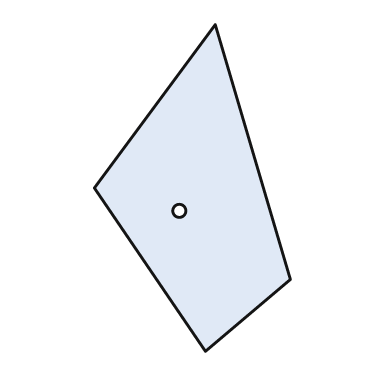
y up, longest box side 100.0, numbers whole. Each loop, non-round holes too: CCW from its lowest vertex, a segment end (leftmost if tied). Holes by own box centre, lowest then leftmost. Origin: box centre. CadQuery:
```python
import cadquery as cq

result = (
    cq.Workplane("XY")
    .moveTo(4.0, -50.0)
    .lineTo(30.0, -28.0)
    .lineTo(7.0, 50.0)
    .lineTo(-30.0, 0.0)
    .close()
    .moveTo(-4.0, -7.0)
    .circle(2.0)
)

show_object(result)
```